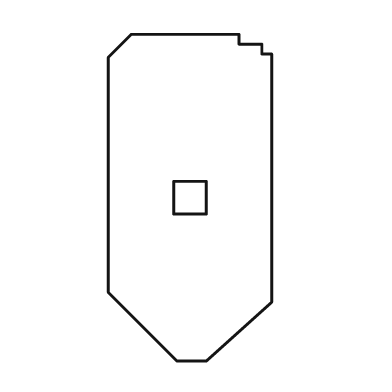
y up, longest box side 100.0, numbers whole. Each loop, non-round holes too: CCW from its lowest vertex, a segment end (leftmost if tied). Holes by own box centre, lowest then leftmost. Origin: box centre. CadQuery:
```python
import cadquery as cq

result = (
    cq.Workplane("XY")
    .moveTo(-4.0, -50.0)
    .lineTo(5.0, -50.0)
    .lineTo(25.0, -32.0)
    .lineTo(25.0, 44.0)
    .lineTo(22.0, 44.0)
    .lineTo(22.0, 47.0)
    .lineTo(15.0, 47.0)
    .lineTo(15.0, 50.0)
    .lineTo(-18.0, 50.0)
    .lineTo(-25.0, 43.0)
    .lineTo(-25.0, -29.0)
    .close()
    .moveTo(-5.0, -5.0)
    .lineTo(5.0, -5.0)
    .lineTo(5.0, 5.0)
    .lineTo(-5.0, 5.0)
    .close()
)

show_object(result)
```